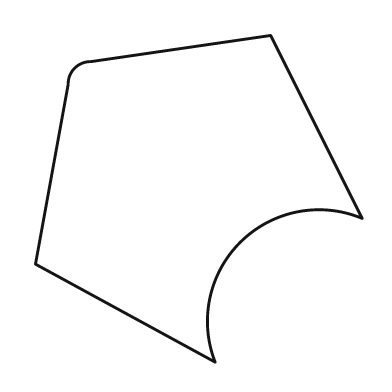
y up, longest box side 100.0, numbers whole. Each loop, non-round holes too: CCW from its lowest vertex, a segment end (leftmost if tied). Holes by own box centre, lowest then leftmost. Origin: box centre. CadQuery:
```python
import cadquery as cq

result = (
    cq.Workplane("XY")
    .moveTo(5.0, -50.0)
    .threePointArc((13.0, -13.0), (50.0, -6.0))
    .lineTo(22.0, 50.0)
    .lineTo(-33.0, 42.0)
    .threePointArc((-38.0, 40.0), (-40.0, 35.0))
    .lineTo(-50.0, -20.0)
    .close()
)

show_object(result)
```